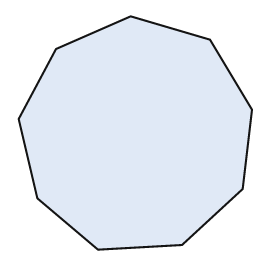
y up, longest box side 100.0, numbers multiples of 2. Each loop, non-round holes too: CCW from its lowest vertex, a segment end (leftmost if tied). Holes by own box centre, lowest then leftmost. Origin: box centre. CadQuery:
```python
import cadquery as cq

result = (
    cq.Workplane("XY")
    .moveTo(-16.0, -50.0)
    .lineTo(20.0, -48.0)
    .lineTo(46.0, -24.0)
    .lineTo(50.0, 10.0)
    .lineTo(32.0, 40.0)
    .lineTo(-2.0, 50.0)
    .lineTo(-34.0, 36.0)
    .lineTo(-50.0, 6.0)
    .lineTo(-42.0, -28.0)
    .close()
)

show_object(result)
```